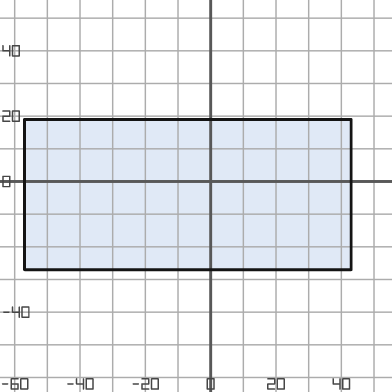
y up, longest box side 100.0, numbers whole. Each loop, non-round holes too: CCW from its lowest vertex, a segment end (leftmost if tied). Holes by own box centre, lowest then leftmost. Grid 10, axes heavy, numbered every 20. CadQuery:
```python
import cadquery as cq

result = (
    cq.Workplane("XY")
    .moveTo(-57.0, -27.0)
    .lineTo(43.0, -27.0)
    .lineTo(43.0, 19.0)
    .lineTo(-57.0, 19.0)
    .close()
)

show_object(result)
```